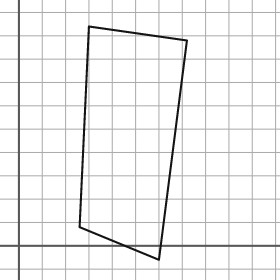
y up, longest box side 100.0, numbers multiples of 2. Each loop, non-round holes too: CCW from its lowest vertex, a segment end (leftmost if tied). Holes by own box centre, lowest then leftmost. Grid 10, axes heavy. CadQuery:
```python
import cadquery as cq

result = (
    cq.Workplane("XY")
    .moveTo(60.0, -6.0)
    .lineTo(72.0, 88.0)
    .lineTo(30.0, 94.0)
    .lineTo(26.0, 8.0)
    .close()
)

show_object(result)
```